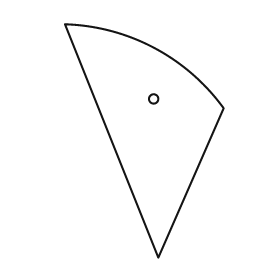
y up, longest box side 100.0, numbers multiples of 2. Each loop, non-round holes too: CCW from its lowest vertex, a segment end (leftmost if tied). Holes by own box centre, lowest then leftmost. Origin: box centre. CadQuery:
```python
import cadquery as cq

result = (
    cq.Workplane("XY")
    .moveTo(6.0, -50.0)
    .lineTo(34.0, 14.0)
    .threePointArc((4.0, 40.0), (-34.0, 50.0))
    .close()
    .moveTo(4.0, 18.0)
    .circle(2.0)
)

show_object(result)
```